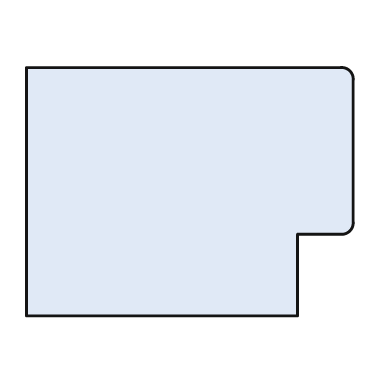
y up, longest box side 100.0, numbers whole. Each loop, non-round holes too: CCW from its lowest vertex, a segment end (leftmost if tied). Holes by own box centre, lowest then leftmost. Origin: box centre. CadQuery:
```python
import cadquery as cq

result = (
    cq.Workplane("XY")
    .moveTo(-50.0, -38.0)
    .lineTo(33.0, -38.0)
    .lineTo(33.0, -13.0)
    .lineTo(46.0, -13.0)
    .threePointArc((49.0, -12.0), (50.0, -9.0))
    .lineTo(50.0, 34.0)
    .threePointArc((49.0, 37.0), (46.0, 38.0))
    .lineTo(-50.0, 38.0)
    .close()
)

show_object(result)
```